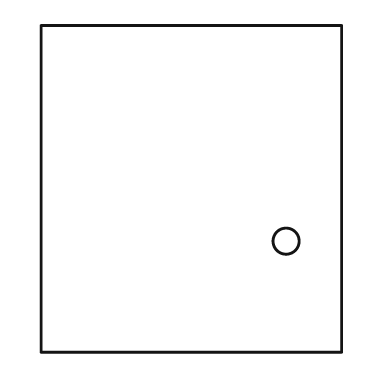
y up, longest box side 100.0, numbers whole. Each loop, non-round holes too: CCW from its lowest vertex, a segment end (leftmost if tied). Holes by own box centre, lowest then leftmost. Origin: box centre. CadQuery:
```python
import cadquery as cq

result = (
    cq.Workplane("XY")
    .moveTo(-46.0, -50.0)
    .lineTo(46.0, -50.0)
    .lineTo(46.0, 50.0)
    .lineTo(-46.0, 50.0)
    .close()
    .moveTo(29.0, -16.0)
    .circle(4.0)
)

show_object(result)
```